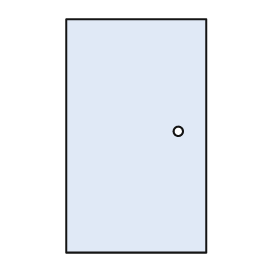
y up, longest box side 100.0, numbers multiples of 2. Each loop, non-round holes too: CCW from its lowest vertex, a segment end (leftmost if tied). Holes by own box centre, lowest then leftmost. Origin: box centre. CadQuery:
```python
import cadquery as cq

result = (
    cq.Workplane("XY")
    .moveTo(-30.0, -50.0)
    .lineTo(30.0, -50.0)
    .lineTo(30.0, 50.0)
    .lineTo(-30.0, 50.0)
    .close()
    .moveTo(18.0, 2.0)
    .circle(2.0)
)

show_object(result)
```